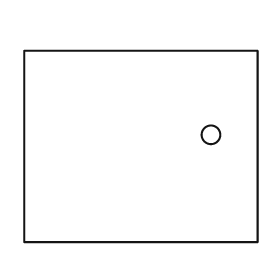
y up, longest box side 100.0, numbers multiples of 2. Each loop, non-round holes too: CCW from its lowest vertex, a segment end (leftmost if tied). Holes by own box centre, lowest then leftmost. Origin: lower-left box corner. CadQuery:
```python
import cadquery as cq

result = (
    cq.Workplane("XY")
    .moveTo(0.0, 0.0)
    .lineTo(100.0, 0.0)
    .lineTo(100.0, 82.0)
    .lineTo(0.0, 82.0)
    .close()
    .moveTo(80.0, 46.0)
    .circle(4.0)
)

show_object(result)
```